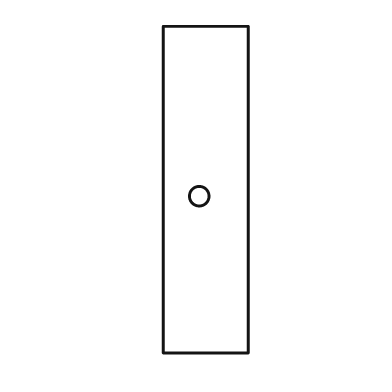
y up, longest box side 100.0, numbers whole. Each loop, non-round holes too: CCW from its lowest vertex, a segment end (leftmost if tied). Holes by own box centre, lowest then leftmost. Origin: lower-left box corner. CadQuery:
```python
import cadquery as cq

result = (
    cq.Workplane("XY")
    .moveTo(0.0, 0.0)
    .lineTo(26.0, 0.0)
    .lineTo(26.0, 100.0)
    .lineTo(0.0, 100.0)
    .close()
    .moveTo(11.0, 48.0)
    .circle(3.0)
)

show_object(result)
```